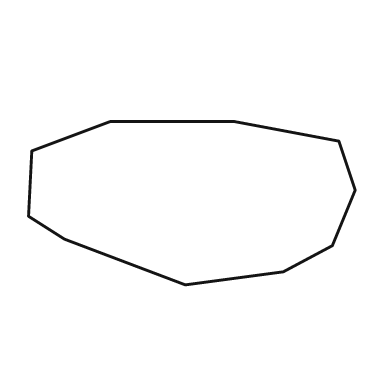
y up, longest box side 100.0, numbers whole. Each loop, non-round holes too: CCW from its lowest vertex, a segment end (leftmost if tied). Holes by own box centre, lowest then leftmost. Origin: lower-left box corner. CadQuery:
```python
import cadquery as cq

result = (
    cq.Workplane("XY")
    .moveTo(48.0, 0.0)
    .lineTo(78.0, 4.0)
    .lineTo(93.0, 12.0)
    .lineTo(100.0, 29.0)
    .lineTo(95.0, 44.0)
    .lineTo(63.0, 50.0)
    .lineTo(25.0, 50.0)
    .lineTo(1.0, 41.0)
    .lineTo(0.0, 21.0)
    .lineTo(11.0, 14.0)
    .close()
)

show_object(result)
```